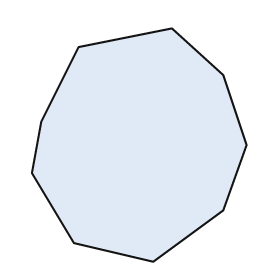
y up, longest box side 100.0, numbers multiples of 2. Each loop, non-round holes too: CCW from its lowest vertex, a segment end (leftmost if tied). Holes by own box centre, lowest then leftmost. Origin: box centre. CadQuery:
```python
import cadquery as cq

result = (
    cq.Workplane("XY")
    .moveTo(6.0, -50.0)
    .lineTo(36.0, -28.0)
    .lineTo(46.0, 0.0)
    .lineTo(36.0, 30.0)
    .lineTo(14.0, 50.0)
    .lineTo(-26.0, 42.0)
    .lineTo(-42.0, 10.0)
    .lineTo(-46.0, -12.0)
    .lineTo(-28.0, -42.0)
    .close()
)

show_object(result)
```